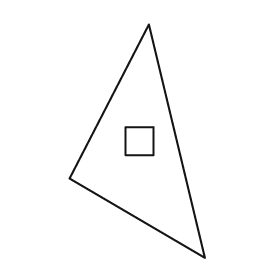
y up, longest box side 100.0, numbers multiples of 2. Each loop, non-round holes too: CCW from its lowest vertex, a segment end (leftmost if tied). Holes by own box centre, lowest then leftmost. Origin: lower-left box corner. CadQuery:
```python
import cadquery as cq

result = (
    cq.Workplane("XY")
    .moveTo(58.0, 0.0)
    .lineTo(34.0, 100.0)
    .lineTo(0.0, 34.0)
    .close()
    .moveTo(24.0, 44.0)
    .lineTo(36.0, 44.0)
    .lineTo(36.0, 56.0)
    .lineTo(24.0, 56.0)
    .close()
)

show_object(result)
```